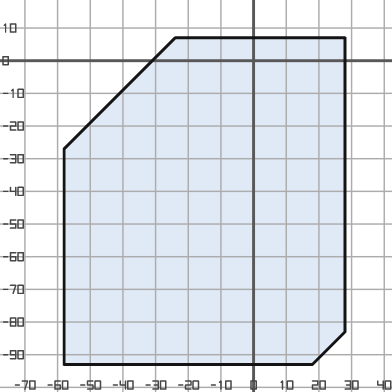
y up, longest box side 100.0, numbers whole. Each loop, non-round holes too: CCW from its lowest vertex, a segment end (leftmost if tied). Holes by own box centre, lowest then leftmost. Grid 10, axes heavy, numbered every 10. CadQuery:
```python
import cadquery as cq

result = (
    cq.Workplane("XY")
    .moveTo(-58.0, -93.0)
    .lineTo(18.0, -93.0)
    .lineTo(28.0, -83.0)
    .lineTo(28.0, 7.0)
    .lineTo(-24.0, 7.0)
    .lineTo(-58.0, -27.0)
    .close()
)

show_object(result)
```